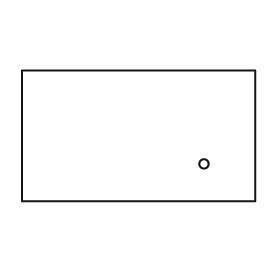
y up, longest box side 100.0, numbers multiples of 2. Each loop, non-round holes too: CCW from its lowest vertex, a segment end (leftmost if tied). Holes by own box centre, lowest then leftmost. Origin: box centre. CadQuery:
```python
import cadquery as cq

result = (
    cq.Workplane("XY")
    .moveTo(-50.0, -28.0)
    .lineTo(50.0, -28.0)
    .lineTo(50.0, 28.0)
    .lineTo(-50.0, 28.0)
    .close()
    .moveTo(28.0, -12.0)
    .circle(2.0)
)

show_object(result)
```